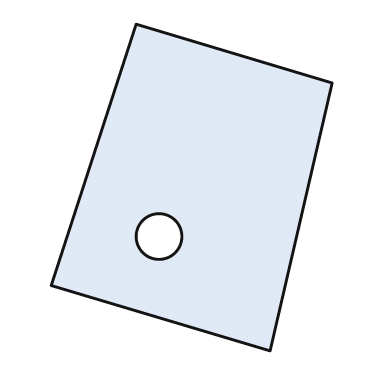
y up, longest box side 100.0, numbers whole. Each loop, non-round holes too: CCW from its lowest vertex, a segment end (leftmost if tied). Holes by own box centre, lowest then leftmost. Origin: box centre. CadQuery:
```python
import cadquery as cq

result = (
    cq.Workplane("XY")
    .moveTo(24.0, -50.0)
    .lineTo(43.0, 32.0)
    .lineTo(-17.0, 50.0)
    .lineTo(-43.0, -30.0)
    .close()
    .moveTo(-10.0, -15.0)
    .circle(7.0)
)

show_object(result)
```